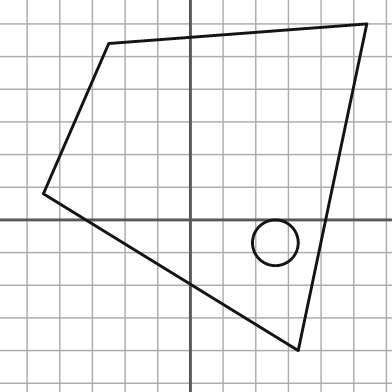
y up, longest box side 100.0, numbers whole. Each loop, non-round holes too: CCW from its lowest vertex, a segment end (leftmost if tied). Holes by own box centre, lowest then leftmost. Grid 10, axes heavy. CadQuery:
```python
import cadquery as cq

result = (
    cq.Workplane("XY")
    .moveTo(33.0, -40.0)
    .lineTo(54.0, 60.0)
    .lineTo(-25.0, 54.0)
    .lineTo(-45.0, 8.0)
    .close()
    .moveTo(26.0, -7.0)
    .circle(7.0)
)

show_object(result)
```